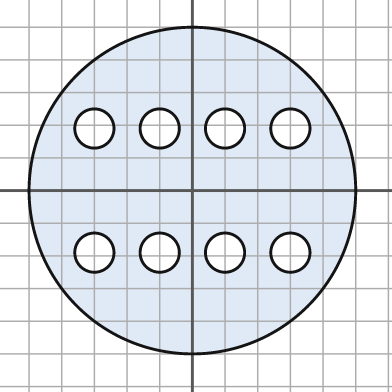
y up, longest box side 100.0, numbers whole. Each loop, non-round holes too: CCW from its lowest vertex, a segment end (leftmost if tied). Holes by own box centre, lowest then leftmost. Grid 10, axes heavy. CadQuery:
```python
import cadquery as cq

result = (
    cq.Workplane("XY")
    .moveTo(0.0, 0.0)
    .circle(50.0)
    .moveTo(-30.0, -19.0)
    .circle(6.0)
    .moveTo(-10.0, -19.0)
    .circle(6.0)
    .moveTo(10.0, -19.0)
    .circle(6.0)
    .moveTo(30.0, -19.0)
    .circle(6.0)
    .moveTo(-30.0, 19.0)
    .circle(6.0)
    .moveTo(-10.0, 19.0)
    .circle(6.0)
    .moveTo(10.0, 19.0)
    .circle(6.0)
    .moveTo(30.0, 19.0)
    .circle(6.0)
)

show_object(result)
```